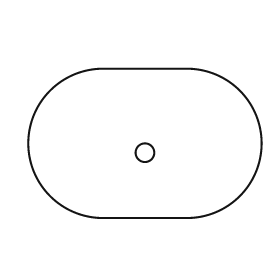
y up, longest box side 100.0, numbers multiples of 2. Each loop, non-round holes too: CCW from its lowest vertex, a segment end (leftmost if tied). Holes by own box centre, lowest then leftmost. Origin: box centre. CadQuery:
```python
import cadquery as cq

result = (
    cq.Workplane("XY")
    .moveTo(-18.0, -32.0)
    .lineTo(18.0, -32.0)
    .threePointArc((50.0, 0.0), (18.0, 32.0))
    .lineTo(-18.0, 32.0)
    .threePointArc((-50.0, 0.0), (-18.0, -32.0))
    .close()
    .moveTo(0.0, -4.0)
    .circle(4.0)
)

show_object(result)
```